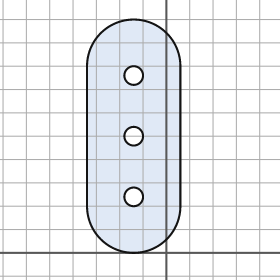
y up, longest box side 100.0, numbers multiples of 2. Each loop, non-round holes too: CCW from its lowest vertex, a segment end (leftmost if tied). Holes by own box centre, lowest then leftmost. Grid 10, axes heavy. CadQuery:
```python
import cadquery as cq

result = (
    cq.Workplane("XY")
    .moveTo(-34.0, 20.0)
    .threePointArc((-14.0, 0.0), (6.0, 20.0))
    .lineTo(6.0, 80.0)
    .threePointArc((-14.0, 100.0), (-34.0, 80.0))
    .close()
    .moveTo(-14.0, 24.0)
    .circle(4.0)
    .moveTo(-14.0, 50.0)
    .circle(4.0)
    .moveTo(-14.0, 76.0)
    .circle(4.0)
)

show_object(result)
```